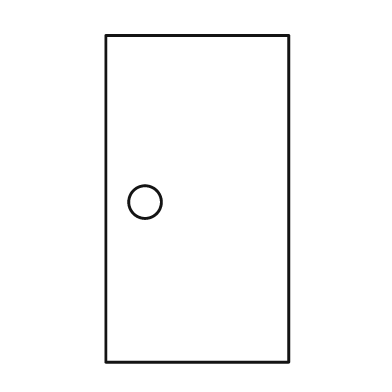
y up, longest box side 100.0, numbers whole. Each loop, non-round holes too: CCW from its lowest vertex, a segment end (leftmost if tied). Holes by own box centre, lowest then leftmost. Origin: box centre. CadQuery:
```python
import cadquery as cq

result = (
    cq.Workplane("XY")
    .moveTo(-28.0, -50.0)
    .lineTo(28.0, -50.0)
    .lineTo(28.0, 50.0)
    .lineTo(-28.0, 50.0)
    .close()
    .moveTo(-16.0, -1.0)
    .circle(5.0)
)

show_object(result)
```